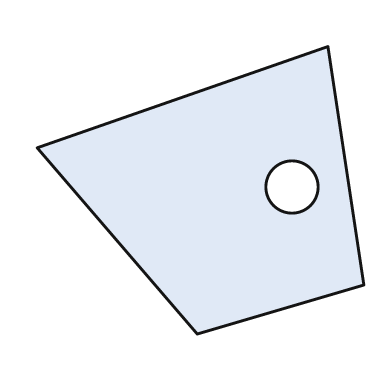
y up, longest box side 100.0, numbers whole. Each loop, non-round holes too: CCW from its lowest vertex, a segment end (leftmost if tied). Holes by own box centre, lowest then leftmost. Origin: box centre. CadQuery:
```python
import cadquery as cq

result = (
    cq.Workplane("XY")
    .moveTo(-1.0, -44.0)
    .lineTo(50.0, -29.0)
    .lineTo(39.0, 44.0)
    .lineTo(-50.0, 13.0)
    .close()
    .moveTo(28.0, 1.0)
    .circle(8.0)
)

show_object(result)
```